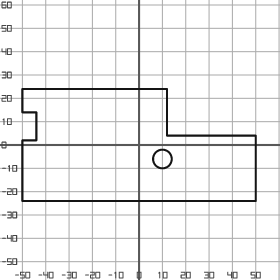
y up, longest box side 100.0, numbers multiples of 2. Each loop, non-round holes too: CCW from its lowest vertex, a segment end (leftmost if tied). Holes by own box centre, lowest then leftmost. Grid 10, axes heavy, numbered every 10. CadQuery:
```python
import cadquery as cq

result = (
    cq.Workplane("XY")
    .moveTo(-50.0, -24.0)
    .lineTo(50.0, -24.0)
    .lineTo(50.0, 4.0)
    .lineTo(12.0, 4.0)
    .lineTo(12.0, 24.0)
    .lineTo(-50.0, 24.0)
    .lineTo(-50.0, 14.0)
    .lineTo(-44.0, 14.0)
    .lineTo(-44.0, 2.0)
    .lineTo(-50.0, 2.0)
    .close()
    .moveTo(10.0, -6.0)
    .circle(4.0)
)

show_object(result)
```